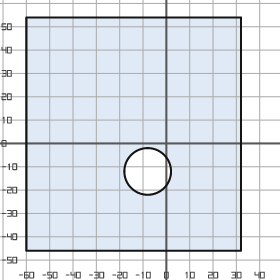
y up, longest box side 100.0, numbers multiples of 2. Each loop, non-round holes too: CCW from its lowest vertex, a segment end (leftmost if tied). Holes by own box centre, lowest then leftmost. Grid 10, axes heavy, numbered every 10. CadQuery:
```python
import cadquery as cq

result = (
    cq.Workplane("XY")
    .moveTo(-60.0, -46.0)
    .lineTo(32.0, -46.0)
    .lineTo(32.0, 54.0)
    .lineTo(-60.0, 54.0)
    .close()
    .moveTo(-8.0, -12.0)
    .circle(10.0)
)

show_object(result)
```